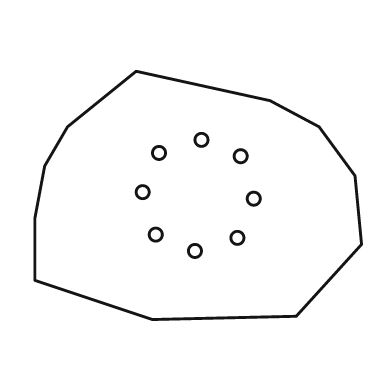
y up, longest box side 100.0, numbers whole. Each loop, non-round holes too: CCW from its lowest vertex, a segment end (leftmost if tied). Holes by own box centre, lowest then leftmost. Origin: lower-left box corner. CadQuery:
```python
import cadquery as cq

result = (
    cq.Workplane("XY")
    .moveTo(36.0, 0.0)
    .lineTo(80.0, 1.0)
    .lineTo(100.0, 23.0)
    .lineTo(98.0, 44.0)
    .lineTo(87.0, 59.0)
    .lineTo(72.0, 67.0)
    .lineTo(31.0, 76.0)
    .lineTo(10.0, 59.0)
    .lineTo(3.0, 47.0)
    .lineTo(0.0, 31.0)
    .lineTo(0.0, 12.0)
    .close()
    .moveTo(49.0, 21.0)
    .circle(2.0)
    .moveTo(62.0, 25.0)
    .circle(2.0)
    .moveTo(37.0, 26.0)
    .circle(2.0)
    .moveTo(67.0, 37.0)
    .circle(2.0)
    .moveTo(33.0, 39.0)
    .circle(2.0)
    .moveTo(63.0, 50.0)
    .circle(2.0)
    .moveTo(38.0, 51.0)
    .circle(2.0)
    .moveTo(51.0, 55.0)
    .circle(2.0)
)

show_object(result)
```